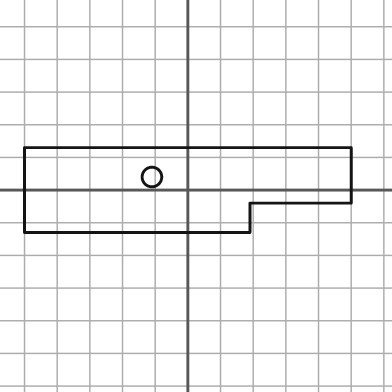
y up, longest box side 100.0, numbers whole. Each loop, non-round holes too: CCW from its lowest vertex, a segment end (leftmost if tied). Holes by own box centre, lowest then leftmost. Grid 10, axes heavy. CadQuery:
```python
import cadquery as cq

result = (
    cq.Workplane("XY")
    .moveTo(-50.0, -13.0)
    .lineTo(19.0, -13.0)
    .lineTo(19.0, -4.0)
    .lineTo(50.0, -4.0)
    .lineTo(50.0, 13.0)
    .lineTo(-50.0, 13.0)
    .close()
    .moveTo(-11.0, 4.0)
    .circle(3.0)
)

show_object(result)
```